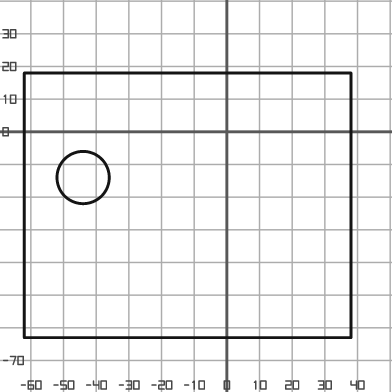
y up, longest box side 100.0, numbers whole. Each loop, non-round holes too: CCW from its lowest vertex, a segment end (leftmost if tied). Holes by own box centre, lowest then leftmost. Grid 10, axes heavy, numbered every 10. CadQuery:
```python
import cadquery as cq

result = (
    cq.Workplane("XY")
    .moveTo(-62.0, -63.0)
    .lineTo(38.0, -63.0)
    .lineTo(38.0, 18.0)
    .lineTo(-62.0, 18.0)
    .close()
    .moveTo(-44.0, -14.0)
    .circle(8.0)
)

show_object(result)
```